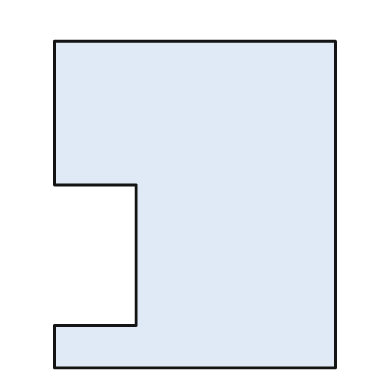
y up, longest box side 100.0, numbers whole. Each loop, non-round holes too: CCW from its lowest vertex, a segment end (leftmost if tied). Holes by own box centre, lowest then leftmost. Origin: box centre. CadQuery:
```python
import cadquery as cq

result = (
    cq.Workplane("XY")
    .moveTo(-43.0, -50.0)
    .lineTo(43.0, -50.0)
    .lineTo(43.0, 50.0)
    .lineTo(-43.0, 50.0)
    .lineTo(-43.0, 6.0)
    .lineTo(-18.0, 6.0)
    .lineTo(-18.0, -37.0)
    .lineTo(-43.0, -37.0)
    .close()
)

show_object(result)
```